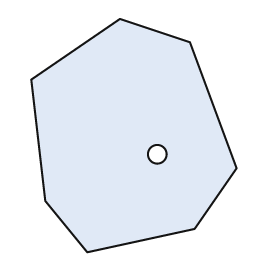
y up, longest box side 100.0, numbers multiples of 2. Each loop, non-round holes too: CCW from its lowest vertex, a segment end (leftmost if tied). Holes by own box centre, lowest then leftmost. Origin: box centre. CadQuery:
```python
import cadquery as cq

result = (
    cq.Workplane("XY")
    .moveTo(-20.0, -50.0)
    .lineTo(26.0, -40.0)
    .lineTo(44.0, -14.0)
    .lineTo(24.0, 40.0)
    .lineTo(-6.0, 50.0)
    .lineTo(-44.0, 24.0)
    .lineTo(-38.0, -28.0)
    .close()
    .moveTo(10.0, -8.0)
    .circle(4.0)
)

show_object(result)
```